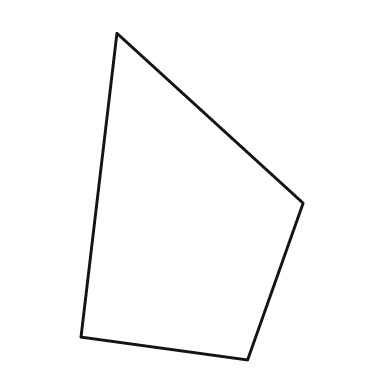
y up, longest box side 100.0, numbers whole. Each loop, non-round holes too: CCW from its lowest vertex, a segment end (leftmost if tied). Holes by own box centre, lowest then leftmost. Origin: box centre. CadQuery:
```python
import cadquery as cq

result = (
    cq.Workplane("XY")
    .moveTo(17.0, -50.0)
    .lineTo(34.0, -2.0)
    .lineTo(-23.0, 50.0)
    .lineTo(-34.0, -43.0)
    .close()
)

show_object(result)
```